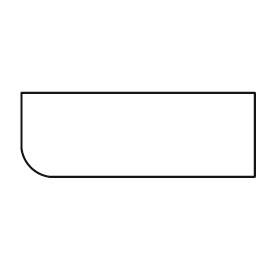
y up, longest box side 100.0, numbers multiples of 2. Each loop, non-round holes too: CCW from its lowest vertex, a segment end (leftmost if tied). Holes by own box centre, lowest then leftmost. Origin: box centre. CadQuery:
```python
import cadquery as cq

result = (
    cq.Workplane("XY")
    .moveTo(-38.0, -18.0)
    .lineTo(50.0, -18.0)
    .lineTo(50.0, 18.0)
    .lineTo(-50.0, 18.0)
    .lineTo(-50.0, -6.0)
    .threePointArc((-46.0, -14.0), (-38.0, -18.0))
    .close()
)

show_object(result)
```